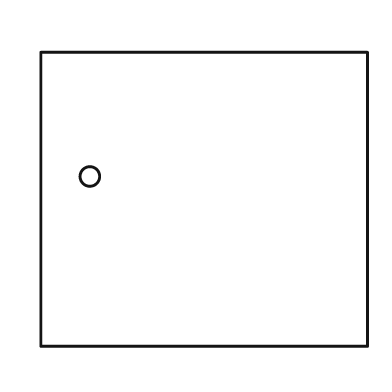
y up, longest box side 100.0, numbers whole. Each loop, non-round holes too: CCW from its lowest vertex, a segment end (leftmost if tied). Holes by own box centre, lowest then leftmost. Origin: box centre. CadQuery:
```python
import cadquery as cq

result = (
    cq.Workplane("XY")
    .moveTo(-50.0, -45.0)
    .lineTo(50.0, -45.0)
    .lineTo(50.0, 45.0)
    .lineTo(-50.0, 45.0)
    .close()
    .moveTo(-35.0, 7.0)
    .circle(3.0)
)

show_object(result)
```